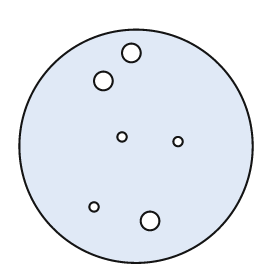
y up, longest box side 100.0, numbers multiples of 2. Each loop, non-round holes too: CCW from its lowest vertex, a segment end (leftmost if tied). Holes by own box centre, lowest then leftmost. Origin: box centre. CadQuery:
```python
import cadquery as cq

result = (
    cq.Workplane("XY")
    .moveTo(0.0, 0.0)
    .circle(50.0)
    .moveTo(6.0, -32.0)
    .circle(4.0)
    .moveTo(-18.0, -26.0)
    .circle(2.0)
    .moveTo(18.0, 2.0)
    .circle(2.0)
    .moveTo(-6.0, 4.0)
    .circle(2.0)
    .moveTo(-14.0, 28.0)
    .circle(4.0)
    .moveTo(-2.0, 40.0)
    .circle(4.0)
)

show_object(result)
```